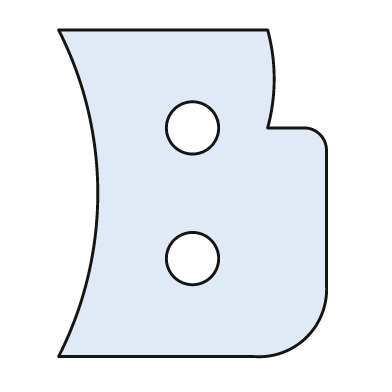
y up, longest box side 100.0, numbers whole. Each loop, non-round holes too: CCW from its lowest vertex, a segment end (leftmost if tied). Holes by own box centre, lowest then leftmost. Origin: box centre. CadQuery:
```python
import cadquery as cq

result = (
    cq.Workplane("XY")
    .moveTo(-41.0, -50.0)
    .lineTo(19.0, -50.0)
    .threePointArc((35.0, -44.0), (41.0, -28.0))
    .lineTo(41.0, 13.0)
    .threePointArc((39.0, 18.0), (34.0, 20.0))
    .lineTo(23.0, 20.0)
    .threePointArc((25.0, 35.0), (23.0, 50.0))
    .lineTo(-41.0, 50.0)
    .threePointArc((-29.0, 0.0), (-41.0, -50.0))
    .close()
    .moveTo(0.0, -20.0)
    .circle(8.0)
    .moveTo(0.0, 20.0)
    .circle(8.0)
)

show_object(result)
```